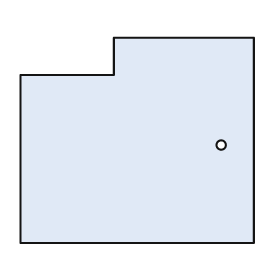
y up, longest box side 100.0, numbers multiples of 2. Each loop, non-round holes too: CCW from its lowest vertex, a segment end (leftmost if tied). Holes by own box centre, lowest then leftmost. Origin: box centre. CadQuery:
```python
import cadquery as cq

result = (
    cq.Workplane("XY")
    .moveTo(-50.0, -44.0)
    .lineTo(50.0, -44.0)
    .lineTo(50.0, 44.0)
    .lineTo(-10.0, 44.0)
    .lineTo(-10.0, 28.0)
    .lineTo(-50.0, 28.0)
    .close()
    .moveTo(36.0, -2.0)
    .circle(2.0)
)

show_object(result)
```